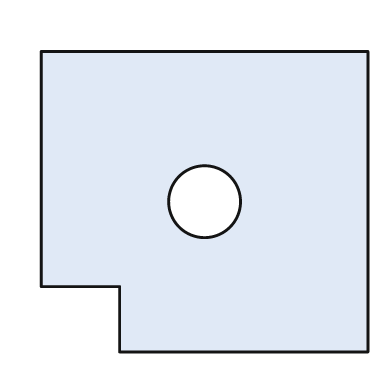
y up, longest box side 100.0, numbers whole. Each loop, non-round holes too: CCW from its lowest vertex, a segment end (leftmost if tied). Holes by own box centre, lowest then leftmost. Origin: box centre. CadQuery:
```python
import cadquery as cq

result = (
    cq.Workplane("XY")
    .moveTo(-26.0, -46.0)
    .lineTo(50.0, -46.0)
    .lineTo(50.0, 46.0)
    .lineTo(-50.0, 46.0)
    .lineTo(-50.0, -26.0)
    .lineTo(-26.0, -26.0)
    .close()
    .moveTo(0.0, 0.0)
    .circle(11.0)
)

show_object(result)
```